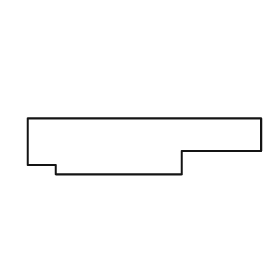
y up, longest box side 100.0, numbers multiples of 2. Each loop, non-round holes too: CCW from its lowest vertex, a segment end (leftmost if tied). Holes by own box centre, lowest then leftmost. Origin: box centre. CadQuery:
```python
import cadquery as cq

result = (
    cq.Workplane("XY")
    .moveTo(-38.0, -12.0)
    .lineTo(16.0, -12.0)
    .lineTo(16.0, -2.0)
    .lineTo(50.0, -2.0)
    .lineTo(50.0, 12.0)
    .lineTo(-50.0, 12.0)
    .lineTo(-50.0, -8.0)
    .lineTo(-38.0, -8.0)
    .close()
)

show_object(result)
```